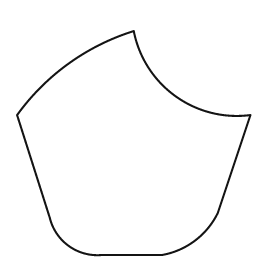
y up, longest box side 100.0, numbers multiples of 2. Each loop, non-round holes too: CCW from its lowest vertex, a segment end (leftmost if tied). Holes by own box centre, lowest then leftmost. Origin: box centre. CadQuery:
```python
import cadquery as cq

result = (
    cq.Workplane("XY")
    .moveTo(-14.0, -48.0)
    .lineTo(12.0, -48.0)
    .threePointArc((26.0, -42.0), (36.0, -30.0))
    .lineTo(50.0, 12.0)
    .threePointArc((18.0, 20.0), (0.0, 48.0))
    .threePointArc((-28.0, 34.0), (-50.0, 12.0))
    .lineTo(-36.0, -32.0)
    .threePointArc((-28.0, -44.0), (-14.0, -48.0))
    .close()
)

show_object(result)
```